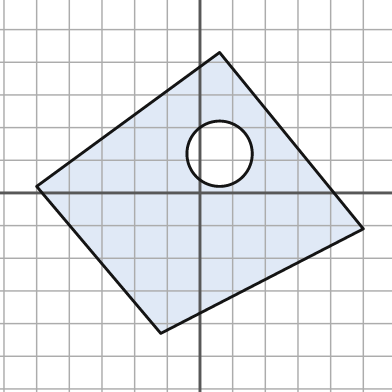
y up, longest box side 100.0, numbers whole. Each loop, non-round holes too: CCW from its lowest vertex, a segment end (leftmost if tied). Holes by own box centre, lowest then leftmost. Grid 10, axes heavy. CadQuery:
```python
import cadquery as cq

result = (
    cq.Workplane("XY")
    .moveTo(-12.0, -43.0)
    .lineTo(50.0, -11.0)
    .lineTo(6.0, 43.0)
    .lineTo(-50.0, 2.0)
    .close()
    .moveTo(6.0, 12.0)
    .circle(10.0)
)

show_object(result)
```